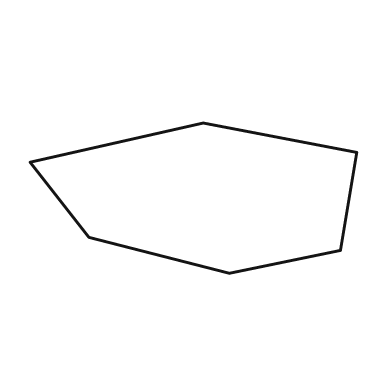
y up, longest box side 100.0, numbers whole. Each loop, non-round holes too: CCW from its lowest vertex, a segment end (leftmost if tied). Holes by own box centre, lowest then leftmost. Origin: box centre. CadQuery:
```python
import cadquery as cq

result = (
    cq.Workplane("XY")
    .moveTo(11.0, -23.0)
    .lineTo(45.0, -16.0)
    .lineTo(50.0, 14.0)
    .lineTo(3.0, 23.0)
    .lineTo(-50.0, 11.0)
    .lineTo(-32.0, -12.0)
    .close()
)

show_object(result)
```